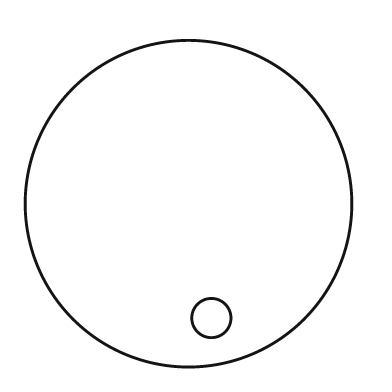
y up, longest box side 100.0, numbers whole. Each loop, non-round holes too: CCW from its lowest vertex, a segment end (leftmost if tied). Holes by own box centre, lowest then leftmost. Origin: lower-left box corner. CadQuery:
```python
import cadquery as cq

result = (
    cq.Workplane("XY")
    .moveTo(50.0, 50.0)
    .circle(50.0)
    .moveTo(57.0, 15.0)
    .circle(6.0)
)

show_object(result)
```